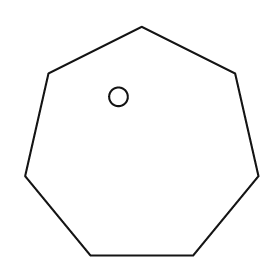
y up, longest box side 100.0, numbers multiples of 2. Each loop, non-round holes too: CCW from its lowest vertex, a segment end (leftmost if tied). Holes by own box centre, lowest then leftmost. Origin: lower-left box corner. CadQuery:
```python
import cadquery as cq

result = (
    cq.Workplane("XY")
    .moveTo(28.0, 0.0)
    .lineTo(72.0, 0.0)
    .lineTo(100.0, 34.0)
    .lineTo(90.0, 78.0)
    .lineTo(50.0, 98.0)
    .lineTo(10.0, 78.0)
    .lineTo(0.0, 34.0)
    .close()
    .moveTo(40.0, 68.0)
    .circle(4.0)
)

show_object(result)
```